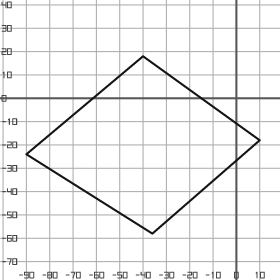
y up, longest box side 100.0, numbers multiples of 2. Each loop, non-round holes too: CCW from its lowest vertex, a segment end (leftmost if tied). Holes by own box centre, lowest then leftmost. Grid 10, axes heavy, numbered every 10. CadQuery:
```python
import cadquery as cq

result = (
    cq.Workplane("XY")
    .moveTo(-36.0, -58.0)
    .lineTo(10.0, -18.0)
    .lineTo(-40.0, 18.0)
    .lineTo(-90.0, -24.0)
    .close()
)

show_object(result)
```